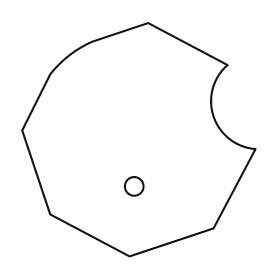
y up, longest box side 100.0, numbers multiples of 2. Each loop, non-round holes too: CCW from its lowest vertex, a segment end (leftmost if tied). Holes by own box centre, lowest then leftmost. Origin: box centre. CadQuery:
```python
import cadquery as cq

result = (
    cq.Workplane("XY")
    .moveTo(-4.0, -50.0)
    .lineTo(32.0, -38.0)
    .lineTo(50.0, -4.0)
    .threePointArc((32.0, 10.0), (38.0, 32.0))
    .lineTo(4.0, 50.0)
    .lineTo(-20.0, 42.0)
    .threePointArc((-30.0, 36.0), (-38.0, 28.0))
    .lineTo(-50.0, 4.0)
    .lineTo(-38.0, -32.0)
    .close()
    .moveTo(-2.0, -20.0)
    .circle(4.0)
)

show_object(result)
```